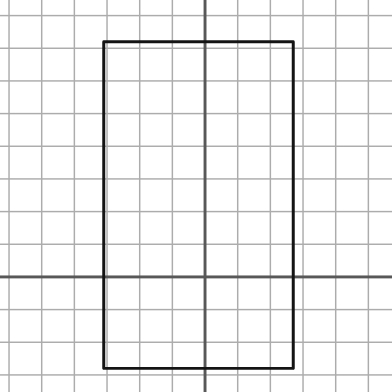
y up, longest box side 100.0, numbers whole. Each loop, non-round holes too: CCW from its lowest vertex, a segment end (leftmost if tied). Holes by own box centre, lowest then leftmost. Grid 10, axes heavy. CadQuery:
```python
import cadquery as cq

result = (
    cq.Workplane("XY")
    .moveTo(-31.0, -28.0)
    .lineTo(27.0, -28.0)
    .lineTo(27.0, 72.0)
    .lineTo(-31.0, 72.0)
    .close()
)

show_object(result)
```